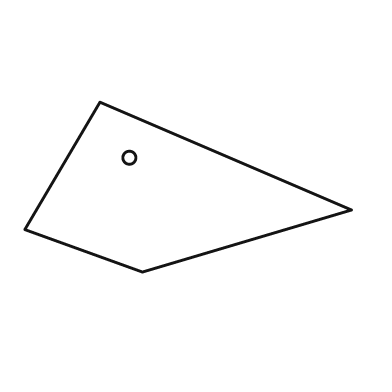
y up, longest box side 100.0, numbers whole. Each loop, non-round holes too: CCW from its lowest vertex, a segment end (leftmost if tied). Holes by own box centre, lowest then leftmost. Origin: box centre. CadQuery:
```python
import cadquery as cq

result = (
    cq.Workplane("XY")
    .moveTo(-14.0, -26.0)
    .lineTo(50.0, -7.0)
    .lineTo(-27.0, 26.0)
    .lineTo(-50.0, -13.0)
    .close()
    .moveTo(-18.0, 9.0)
    .circle(2.0)
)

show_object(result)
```